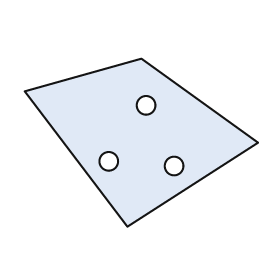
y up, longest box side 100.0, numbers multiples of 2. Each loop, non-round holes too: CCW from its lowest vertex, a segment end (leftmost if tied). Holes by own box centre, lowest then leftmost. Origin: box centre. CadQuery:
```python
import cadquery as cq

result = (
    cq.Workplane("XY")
    .moveTo(-6.0, -36.0)
    .lineTo(50.0, 0.0)
    .lineTo(0.0, 36.0)
    .lineTo(-50.0, 22.0)
    .close()
    .moveTo(14.0, -10.0)
    .circle(4.0)
    .moveTo(-14.0, -8.0)
    .circle(4.0)
    .moveTo(2.0, 16.0)
    .circle(4.0)
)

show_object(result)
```